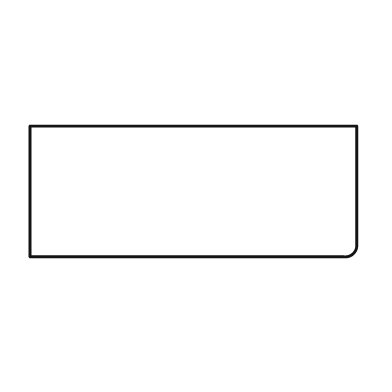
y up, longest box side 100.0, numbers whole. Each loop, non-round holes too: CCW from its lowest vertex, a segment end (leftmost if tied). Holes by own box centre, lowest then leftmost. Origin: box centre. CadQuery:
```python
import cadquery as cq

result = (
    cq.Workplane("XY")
    .moveTo(-50.0, -20.0)
    .lineTo(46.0, -20.0)
    .threePointArc((49.0, -19.0), (50.0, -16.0))
    .lineTo(50.0, 20.0)
    .lineTo(-50.0, 20.0)
    .close()
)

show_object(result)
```